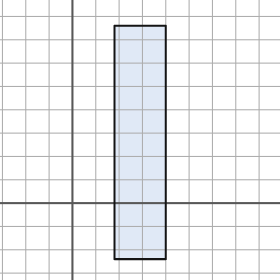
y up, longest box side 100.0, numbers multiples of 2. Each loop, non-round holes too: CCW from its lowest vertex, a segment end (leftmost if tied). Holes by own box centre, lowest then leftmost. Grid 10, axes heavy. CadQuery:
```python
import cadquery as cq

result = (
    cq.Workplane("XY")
    .moveTo(18.0, -24.0)
    .lineTo(40.0, -24.0)
    .lineTo(40.0, 76.0)
    .lineTo(18.0, 76.0)
    .close()
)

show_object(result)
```